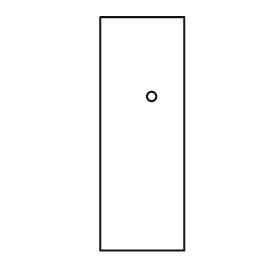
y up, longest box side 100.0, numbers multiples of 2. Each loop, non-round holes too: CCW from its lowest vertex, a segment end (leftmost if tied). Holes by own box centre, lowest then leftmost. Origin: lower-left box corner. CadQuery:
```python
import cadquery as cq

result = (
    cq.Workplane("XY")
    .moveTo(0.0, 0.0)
    .lineTo(36.0, 0.0)
    .lineTo(36.0, 100.0)
    .lineTo(0.0, 100.0)
    .close()
    .moveTo(22.0, 66.0)
    .circle(2.0)
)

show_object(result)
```